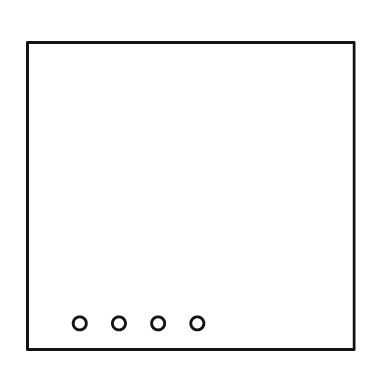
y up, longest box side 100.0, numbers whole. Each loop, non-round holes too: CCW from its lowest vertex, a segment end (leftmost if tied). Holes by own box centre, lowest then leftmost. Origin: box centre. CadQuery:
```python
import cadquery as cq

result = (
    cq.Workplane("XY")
    .moveTo(-50.0, -47.0)
    .lineTo(50.0, -47.0)
    .lineTo(50.0, 47.0)
    .lineTo(-50.0, 47.0)
    .close()
    .moveTo(-34.0, -39.0)
    .circle(2.0)
    .moveTo(-22.0, -39.0)
    .circle(2.0)
    .moveTo(-10.0, -39.0)
    .circle(2.0)
    .moveTo(2.0, -39.0)
    .circle(2.0)
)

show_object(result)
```